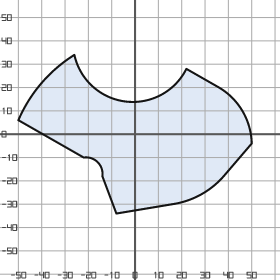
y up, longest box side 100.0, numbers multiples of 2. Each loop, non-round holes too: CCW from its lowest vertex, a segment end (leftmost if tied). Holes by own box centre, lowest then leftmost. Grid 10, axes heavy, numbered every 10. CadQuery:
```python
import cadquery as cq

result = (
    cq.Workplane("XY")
    .moveTo(-8.0, -34.0)
    .lineTo(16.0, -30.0)
    .threePointArc((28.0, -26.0), (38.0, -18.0))
    .lineTo(50.0, -4.0)
    .threePointArc((46.0, 10.0), (36.0, 20.0))
    .lineTo(22.0, 28.0)
    .threePointArc((-4.0, 14.0), (-26.0, 34.0))
    .threePointArc((-40.0, 22.0), (-50.0, 6.0))
    .lineTo(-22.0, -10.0)
    .threePointArc((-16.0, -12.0), (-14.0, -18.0))
    .close()
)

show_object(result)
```